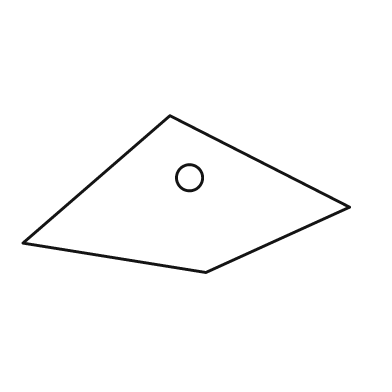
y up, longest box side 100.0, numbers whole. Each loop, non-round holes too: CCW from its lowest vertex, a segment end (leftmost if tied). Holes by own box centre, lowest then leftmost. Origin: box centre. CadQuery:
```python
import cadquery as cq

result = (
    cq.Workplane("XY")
    .moveTo(6.0, -24.0)
    .lineTo(50.0, -4.0)
    .lineTo(-5.0, 24.0)
    .lineTo(-50.0, -15.0)
    .close()
    .moveTo(1.0, 5.0)
    .circle(4.0)
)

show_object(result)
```